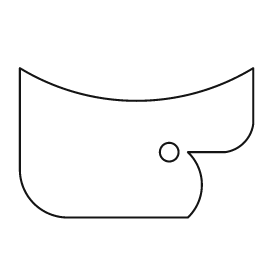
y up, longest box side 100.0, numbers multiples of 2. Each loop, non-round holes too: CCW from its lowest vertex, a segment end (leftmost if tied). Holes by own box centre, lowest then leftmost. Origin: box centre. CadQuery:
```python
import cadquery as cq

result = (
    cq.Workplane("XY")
    .moveTo(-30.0, -32.0)
    .lineTo(22.0, -32.0)
    .threePointArc((28.0, -18.0), (22.0, -4.0))
    .lineTo(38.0, -4.0)
    .threePointArc((46.0, 0.0), (50.0, 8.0))
    .lineTo(50.0, 32.0)
    .threePointArc((0.0, 18.0), (-50.0, 32.0))
    .lineTo(-50.0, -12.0)
    .threePointArc((-44.0, -26.0), (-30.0, -32.0))
    .close()
    .moveTo(14.0, -4.0)
    .circle(4.0)
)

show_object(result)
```